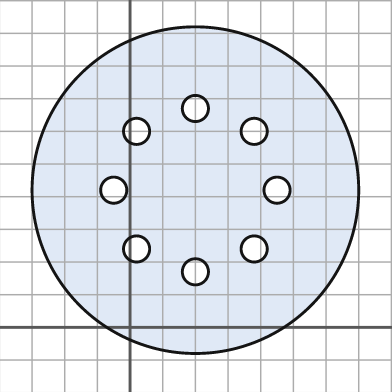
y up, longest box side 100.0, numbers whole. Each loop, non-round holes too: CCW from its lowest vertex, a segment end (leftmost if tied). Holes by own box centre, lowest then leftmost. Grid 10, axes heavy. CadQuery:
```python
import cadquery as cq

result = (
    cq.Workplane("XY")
    .moveTo(20.0, 42.0)
    .circle(50.0)
    .moveTo(20.0, 17.0)
    .circle(4.0)
    .moveTo(2.0, 24.0)
    .circle(4.0)
    .moveTo(38.0, 24.0)
    .circle(4.0)
    .moveTo(-5.0, 42.0)
    .circle(4.0)
    .moveTo(45.0, 42.0)
    .circle(4.0)
    .moveTo(2.0, 60.0)
    .circle(4.0)
    .moveTo(38.0, 60.0)
    .circle(4.0)
    .moveTo(20.0, 67.0)
    .circle(4.0)
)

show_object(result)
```